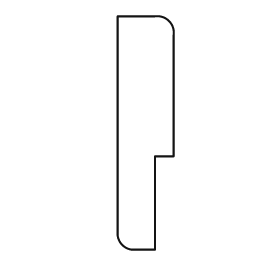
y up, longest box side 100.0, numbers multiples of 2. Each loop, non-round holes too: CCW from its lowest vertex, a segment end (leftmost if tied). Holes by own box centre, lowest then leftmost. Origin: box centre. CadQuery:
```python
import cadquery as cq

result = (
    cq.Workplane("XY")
    .moveTo(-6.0, -50.0)
    .lineTo(4.0, -50.0)
    .lineTo(4.0, -10.0)
    .lineTo(12.0, -10.0)
    .lineTo(12.0, 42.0)
    .threePointArc((10.0, 48.0), (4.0, 50.0))
    .lineTo(-12.0, 50.0)
    .lineTo(-12.0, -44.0)
    .threePointArc((-10.0, -48.0), (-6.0, -50.0))
    .close()
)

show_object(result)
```